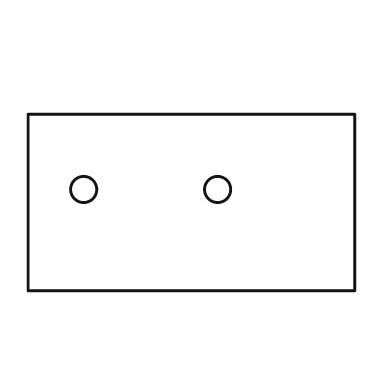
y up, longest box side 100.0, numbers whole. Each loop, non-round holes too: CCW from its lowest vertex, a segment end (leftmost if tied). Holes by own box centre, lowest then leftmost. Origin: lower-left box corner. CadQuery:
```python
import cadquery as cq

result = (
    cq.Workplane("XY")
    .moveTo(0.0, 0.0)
    .lineTo(100.0, 0.0)
    .lineTo(100.0, 54.0)
    .lineTo(0.0, 54.0)
    .close()
    .moveTo(17.0, 31.0)
    .circle(4.0)
    .moveTo(58.0, 31.0)
    .circle(4.0)
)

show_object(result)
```